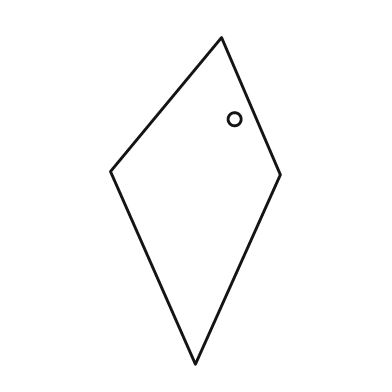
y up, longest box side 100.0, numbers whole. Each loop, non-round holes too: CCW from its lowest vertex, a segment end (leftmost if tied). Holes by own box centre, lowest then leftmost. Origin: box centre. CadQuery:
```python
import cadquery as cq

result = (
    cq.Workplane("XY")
    .moveTo(0.0, -50.0)
    .lineTo(26.0, 8.0)
    .lineTo(8.0, 50.0)
    .lineTo(-26.0, 9.0)
    .close()
    .moveTo(12.0, 25.0)
    .circle(2.0)
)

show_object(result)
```